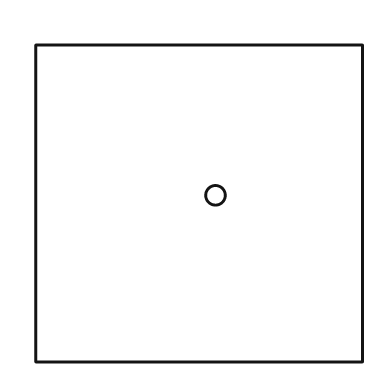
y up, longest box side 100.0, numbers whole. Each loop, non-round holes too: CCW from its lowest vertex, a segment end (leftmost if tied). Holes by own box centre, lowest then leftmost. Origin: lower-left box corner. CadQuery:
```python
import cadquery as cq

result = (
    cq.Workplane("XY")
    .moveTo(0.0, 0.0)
    .lineTo(100.0, 0.0)
    .lineTo(100.0, 97.0)
    .lineTo(0.0, 97.0)
    .close()
    .moveTo(55.0, 51.0)
    .circle(3.0)
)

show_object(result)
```